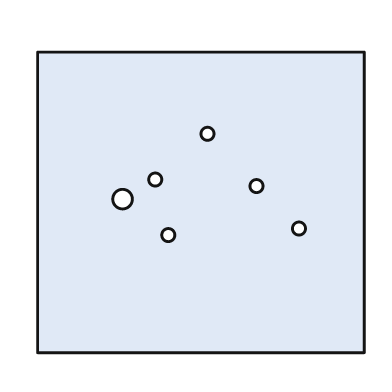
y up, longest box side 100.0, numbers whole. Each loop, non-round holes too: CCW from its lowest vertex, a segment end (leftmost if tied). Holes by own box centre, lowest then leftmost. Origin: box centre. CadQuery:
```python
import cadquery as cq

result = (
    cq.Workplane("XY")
    .moveTo(-50.0, -46.0)
    .lineTo(50.0, -46.0)
    .lineTo(50.0, 46.0)
    .lineTo(-50.0, 46.0)
    .close()
    .moveTo(-10.0, -10.0)
    .circle(2.0)
    .moveTo(30.0, -8.0)
    .circle(2.0)
    .moveTo(-24.0, 1.0)
    .circle(3.0)
    .moveTo(17.0, 5.0)
    .circle(2.0)
    .moveTo(-14.0, 7.0)
    .circle(2.0)
    .moveTo(2.0, 21.0)
    .circle(2.0)
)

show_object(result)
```